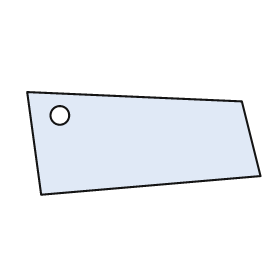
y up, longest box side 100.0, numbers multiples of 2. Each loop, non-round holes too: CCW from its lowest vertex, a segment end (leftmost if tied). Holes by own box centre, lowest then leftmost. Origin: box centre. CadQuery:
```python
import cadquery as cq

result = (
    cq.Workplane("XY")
    .moveTo(-44.0, -22.0)
    .lineTo(50.0, -14.0)
    .lineTo(42.0, 18.0)
    .lineTo(-50.0, 22.0)
    .close()
    .moveTo(-36.0, 12.0)
    .circle(4.0)
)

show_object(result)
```